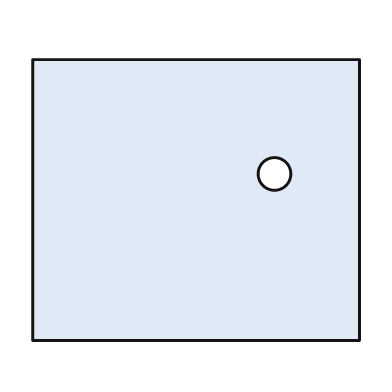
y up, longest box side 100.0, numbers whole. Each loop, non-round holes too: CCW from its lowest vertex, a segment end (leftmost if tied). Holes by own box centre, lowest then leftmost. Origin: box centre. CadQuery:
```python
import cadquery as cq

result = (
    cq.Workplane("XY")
    .moveTo(-50.0, -43.0)
    .lineTo(50.0, -43.0)
    .lineTo(50.0, 43.0)
    .lineTo(-50.0, 43.0)
    .close()
    .moveTo(24.0, 8.0)
    .circle(5.0)
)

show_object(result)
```